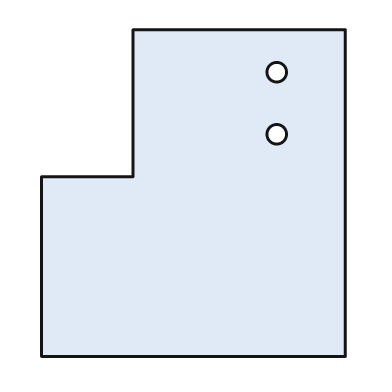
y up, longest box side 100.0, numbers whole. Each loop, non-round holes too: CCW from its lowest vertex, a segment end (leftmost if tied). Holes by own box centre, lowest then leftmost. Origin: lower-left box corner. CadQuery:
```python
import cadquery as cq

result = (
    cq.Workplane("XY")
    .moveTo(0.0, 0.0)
    .lineTo(93.0, 0.0)
    .lineTo(93.0, 100.0)
    .lineTo(28.0, 100.0)
    .lineTo(28.0, 55.0)
    .lineTo(0.0, 55.0)
    .close()
    .moveTo(72.0, 68.0)
    .circle(3.0)
    .moveTo(72.0, 87.0)
    .circle(3.0)
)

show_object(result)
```